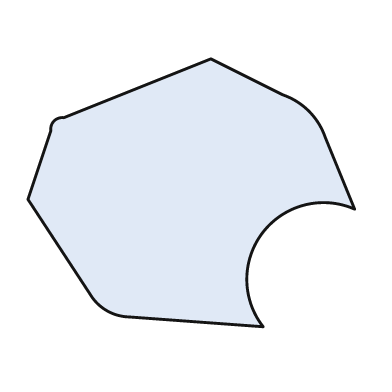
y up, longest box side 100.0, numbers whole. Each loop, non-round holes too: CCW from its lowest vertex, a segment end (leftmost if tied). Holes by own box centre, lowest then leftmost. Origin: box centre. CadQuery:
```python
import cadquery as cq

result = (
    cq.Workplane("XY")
    .moveTo(22.0, -41.0)
    .threePointArc((22.0, -12.0), (50.0, -5.0))
    .lineTo(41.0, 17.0)
    .threePointArc((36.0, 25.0), (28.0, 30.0))
    .lineTo(6.0, 41.0)
    .lineTo(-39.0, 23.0)
    .threePointArc((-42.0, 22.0), (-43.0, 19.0))
    .lineTo(-50.0, -2.0)
    .lineTo(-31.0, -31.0)
    .threePointArc((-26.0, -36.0), (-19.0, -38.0))
    .close()
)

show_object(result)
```